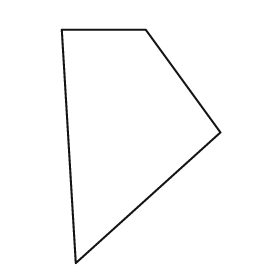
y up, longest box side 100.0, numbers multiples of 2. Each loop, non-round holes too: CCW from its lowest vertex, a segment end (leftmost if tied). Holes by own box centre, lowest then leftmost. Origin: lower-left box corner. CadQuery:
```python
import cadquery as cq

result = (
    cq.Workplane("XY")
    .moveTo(6.0, 0.0)
    .lineTo(68.0, 56.0)
    .lineTo(36.0, 100.0)
    .lineTo(0.0, 100.0)
    .close()
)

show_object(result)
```